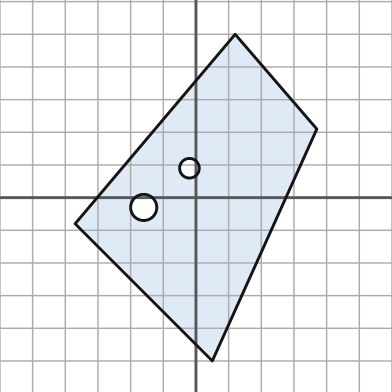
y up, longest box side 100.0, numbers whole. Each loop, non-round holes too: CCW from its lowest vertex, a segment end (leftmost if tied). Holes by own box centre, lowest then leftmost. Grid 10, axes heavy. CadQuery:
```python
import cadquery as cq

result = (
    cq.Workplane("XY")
    .moveTo(5.0, -50.0)
    .lineTo(37.0, 21.0)
    .lineTo(12.0, 50.0)
    .lineTo(-37.0, -8.0)
    .close()
    .moveTo(-16.0, -3.0)
    .circle(4.0)
    .moveTo(-2.0, 9.0)
    .circle(3.0)
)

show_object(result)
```